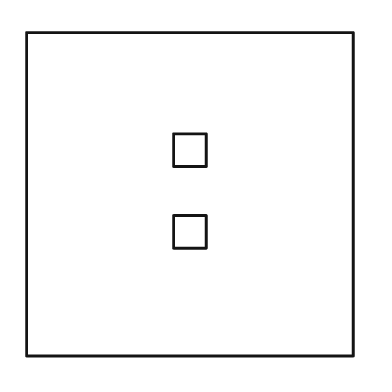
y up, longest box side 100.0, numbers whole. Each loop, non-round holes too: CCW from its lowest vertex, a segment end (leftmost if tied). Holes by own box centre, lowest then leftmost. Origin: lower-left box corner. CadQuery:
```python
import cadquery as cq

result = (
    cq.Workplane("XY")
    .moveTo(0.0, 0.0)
    .lineTo(100.0, 0.0)
    .lineTo(100.0, 99.0)
    .lineTo(0.0, 99.0)
    .close()
    .moveTo(45.0, 33.0)
    .lineTo(55.0, 33.0)
    .lineTo(55.0, 43.0)
    .lineTo(45.0, 43.0)
    .close()
    .moveTo(45.0, 58.0)
    .lineTo(55.0, 58.0)
    .lineTo(55.0, 68.0)
    .lineTo(45.0, 68.0)
    .close()
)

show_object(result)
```